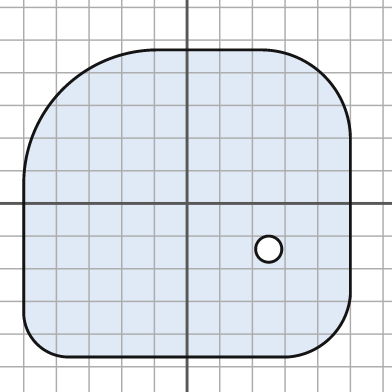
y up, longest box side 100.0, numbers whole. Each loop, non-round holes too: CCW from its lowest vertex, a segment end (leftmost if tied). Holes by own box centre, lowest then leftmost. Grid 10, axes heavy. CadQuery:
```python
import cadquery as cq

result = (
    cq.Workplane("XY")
    .moveTo(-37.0, -47.0)
    .lineTo(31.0, -47.0)
    .threePointArc((44.0, -41.0), (50.0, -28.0))
    .lineTo(50.0, 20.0)
    .threePointArc((42.0, 39.0), (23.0, 47.0))
    .lineTo(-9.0, 47.0)
    .threePointArc((-38.0, 35.0), (-50.0, 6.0))
    .lineTo(-50.0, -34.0)
    .threePointArc((-46.0, -43.0), (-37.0, -47.0))
    .close()
    .moveTo(25.0, -14.0)
    .circle(4.0)
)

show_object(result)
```